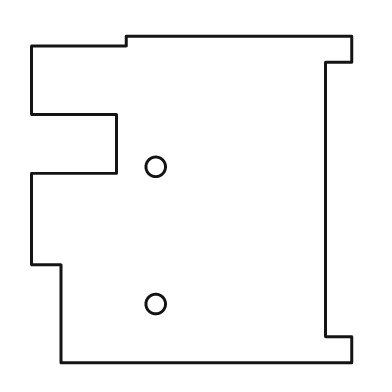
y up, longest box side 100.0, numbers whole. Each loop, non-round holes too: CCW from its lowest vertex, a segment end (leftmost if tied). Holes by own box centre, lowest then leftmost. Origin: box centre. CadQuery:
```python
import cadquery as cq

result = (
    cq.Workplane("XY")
    .moveTo(-40.0, -50.0)
    .lineTo(49.0, -50.0)
    .lineTo(49.0, -42.0)
    .lineTo(41.0, -42.0)
    .lineTo(41.0, 42.0)
    .lineTo(49.0, 42.0)
    .lineTo(49.0, 50.0)
    .lineTo(-20.0, 50.0)
    .lineTo(-20.0, 47.0)
    .lineTo(-49.0, 47.0)
    .lineTo(-49.0, 26.0)
    .lineTo(-23.0, 26.0)
    .lineTo(-23.0, 8.0)
    .lineTo(-49.0, 8.0)
    .lineTo(-49.0, -20.0)
    .lineTo(-40.0, -20.0)
    .close()
    .moveTo(-11.0, -32.0)
    .circle(3.0)
    .moveTo(-11.0, 10.0)
    .circle(3.0)
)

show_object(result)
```